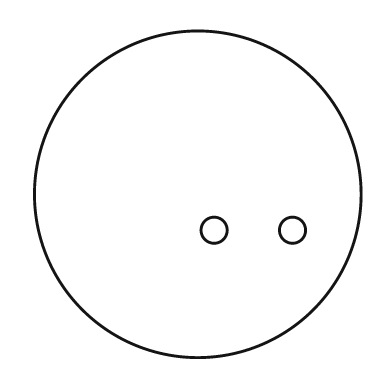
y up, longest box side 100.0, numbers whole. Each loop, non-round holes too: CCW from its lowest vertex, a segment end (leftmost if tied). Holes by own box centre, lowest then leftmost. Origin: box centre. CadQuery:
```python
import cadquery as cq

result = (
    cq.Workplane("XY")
    .moveTo(0.0, 0.0)
    .circle(50.0)
    .moveTo(5.0, -11.0)
    .circle(4.0)
    .moveTo(29.0, -11.0)
    .circle(4.0)
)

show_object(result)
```